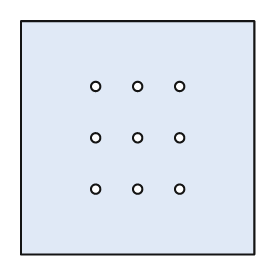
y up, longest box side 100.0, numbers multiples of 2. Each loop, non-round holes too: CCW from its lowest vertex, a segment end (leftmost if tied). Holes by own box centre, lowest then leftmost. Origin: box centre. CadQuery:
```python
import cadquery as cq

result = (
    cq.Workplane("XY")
    .moveTo(-50.0, -50.0)
    .lineTo(50.0, -50.0)
    .lineTo(50.0, 50.0)
    .lineTo(-50.0, 50.0)
    .close()
    .moveTo(-18.0, -22.0)
    .circle(2.0)
    .moveTo(0.0, -22.0)
    .circle(2.0)
    .moveTo(18.0, -22.0)
    .circle(2.0)
    .moveTo(-18.0, 0.0)
    .circle(2.0)
    .moveTo(0.0, 0.0)
    .circle(2.0)
    .moveTo(18.0, 0.0)
    .circle(2.0)
    .moveTo(-18.0, 22.0)
    .circle(2.0)
    .moveTo(0.0, 22.0)
    .circle(2.0)
    .moveTo(18.0, 22.0)
    .circle(2.0)
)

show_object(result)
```